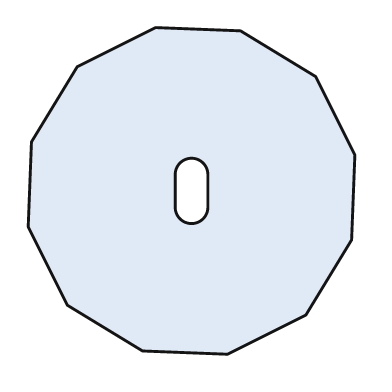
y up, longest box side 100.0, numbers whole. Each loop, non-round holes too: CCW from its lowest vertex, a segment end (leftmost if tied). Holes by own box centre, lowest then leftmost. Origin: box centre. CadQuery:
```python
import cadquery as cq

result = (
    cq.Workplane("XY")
    .moveTo(11.0, -50.0)
    .lineTo(35.0, -38.0)
    .lineTo(49.0, -15.0)
    .lineTo(50.0, 11.0)
    .lineTo(38.0, 35.0)
    .lineTo(15.0, 49.0)
    .lineTo(-11.0, 50.0)
    .lineTo(-35.0, 38.0)
    .lineTo(-49.0, 15.0)
    .lineTo(-50.0, -11.0)
    .lineTo(-38.0, -35.0)
    .lineTo(-15.0, -49.0)
    .close()
    .moveTo(-5.0, -5.0)
    .threePointArc((0.0, -10.0), (5.0, -5.0))
    .lineTo(5.0, 5.0)
    .threePointArc((0.0, 10.0), (-5.0, 5.0))
    .close()
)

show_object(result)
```